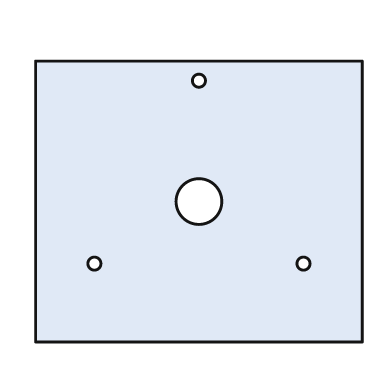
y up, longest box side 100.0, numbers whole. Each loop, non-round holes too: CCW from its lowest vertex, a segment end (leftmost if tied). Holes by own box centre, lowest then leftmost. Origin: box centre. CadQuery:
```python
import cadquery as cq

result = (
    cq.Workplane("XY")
    .moveTo(-50.0, -43.0)
    .lineTo(50.0, -43.0)
    .lineTo(50.0, 43.0)
    .lineTo(-50.0, 43.0)
    .close()
    .moveTo(-32.0, -19.0)
    .circle(2.0)
    .moveTo(32.0, -19.0)
    .circle(2.0)
    .moveTo(0.0, 0.0)
    .circle(7.0)
    .moveTo(0.0, 37.0)
    .circle(2.0)
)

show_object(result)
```